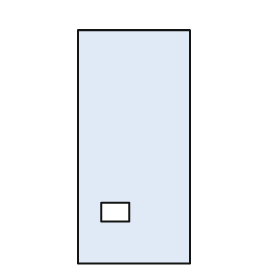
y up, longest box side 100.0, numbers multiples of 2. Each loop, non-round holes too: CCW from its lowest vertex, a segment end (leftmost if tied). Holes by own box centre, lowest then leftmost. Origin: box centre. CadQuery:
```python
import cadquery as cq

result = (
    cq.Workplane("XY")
    .moveTo(-24.0, -50.0)
    .lineTo(24.0, -50.0)
    .lineTo(24.0, 50.0)
    .lineTo(-24.0, 50.0)
    .close()
    .moveTo(-14.0, -32.0)
    .lineTo(-2.0, -32.0)
    .lineTo(-2.0, -24.0)
    .lineTo(-14.0, -24.0)
    .close()
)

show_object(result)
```